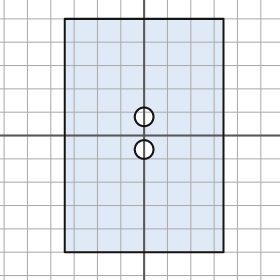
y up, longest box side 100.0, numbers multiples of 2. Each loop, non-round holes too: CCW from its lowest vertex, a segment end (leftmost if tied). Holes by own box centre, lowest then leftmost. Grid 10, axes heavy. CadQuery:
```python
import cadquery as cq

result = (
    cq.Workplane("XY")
    .moveTo(-34.0, -50.0)
    .lineTo(34.0, -50.0)
    .lineTo(34.0, 50.0)
    .lineTo(-34.0, 50.0)
    .close()
    .moveTo(0.0, -6.0)
    .circle(4.0)
    .moveTo(0.0, 8.0)
    .circle(4.0)
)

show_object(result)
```